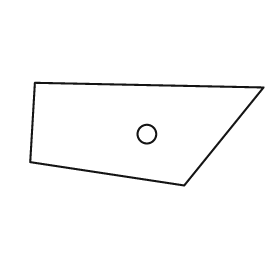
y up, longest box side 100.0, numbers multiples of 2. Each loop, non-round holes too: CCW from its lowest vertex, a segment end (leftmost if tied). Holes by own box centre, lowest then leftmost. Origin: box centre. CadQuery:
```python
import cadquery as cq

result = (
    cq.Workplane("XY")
    .moveTo(16.0, -22.0)
    .lineTo(50.0, 20.0)
    .lineTo(-48.0, 22.0)
    .lineTo(-50.0, -12.0)
    .close()
    .moveTo(0.0, 0.0)
    .circle(4.0)
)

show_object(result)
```